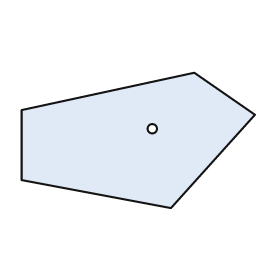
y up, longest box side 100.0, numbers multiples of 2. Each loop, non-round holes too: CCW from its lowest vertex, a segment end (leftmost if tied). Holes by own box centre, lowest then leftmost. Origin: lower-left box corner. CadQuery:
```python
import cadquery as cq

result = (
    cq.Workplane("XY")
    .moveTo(64.0, 0.0)
    .lineTo(100.0, 40.0)
    .lineTo(74.0, 58.0)
    .lineTo(0.0, 42.0)
    .lineTo(0.0, 12.0)
    .close()
    .moveTo(56.0, 34.0)
    .circle(2.0)
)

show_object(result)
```